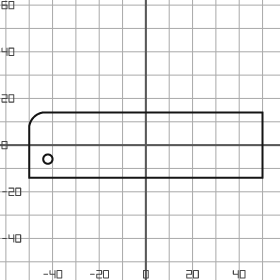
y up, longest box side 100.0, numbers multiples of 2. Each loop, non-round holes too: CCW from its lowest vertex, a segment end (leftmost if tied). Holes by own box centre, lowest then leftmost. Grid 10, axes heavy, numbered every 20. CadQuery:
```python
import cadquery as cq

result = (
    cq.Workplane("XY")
    .moveTo(-50.0, -14.0)
    .lineTo(50.0, -14.0)
    .lineTo(50.0, 14.0)
    .lineTo(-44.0, 14.0)
    .threePointArc((-48.0, 12.0), (-50.0, 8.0))
    .close()
    .moveTo(-42.0, -6.0)
    .circle(2.0)
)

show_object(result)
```